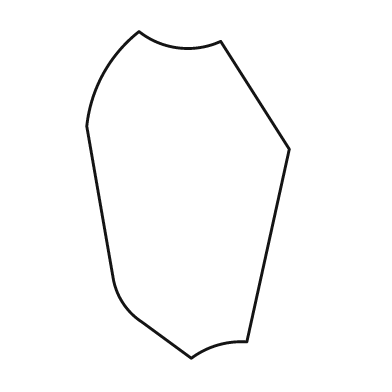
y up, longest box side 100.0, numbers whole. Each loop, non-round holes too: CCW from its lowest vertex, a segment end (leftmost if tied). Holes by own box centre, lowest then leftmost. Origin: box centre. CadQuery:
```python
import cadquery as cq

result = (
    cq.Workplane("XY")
    .moveTo(1.0, -50.0)
    .threePointArc((9.0, -46.0), (18.0, -45.0))
    .lineTo(31.0, 14.0)
    .lineTo(10.0, 47.0)
    .threePointArc((-3.0, 45.0), (-15.0, 50.0))
    .threePointArc((-26.0, 37.0), (-31.0, 21.0))
    .lineTo(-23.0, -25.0)
    .threePointArc((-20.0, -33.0), (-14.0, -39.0))
    .close()
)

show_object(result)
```